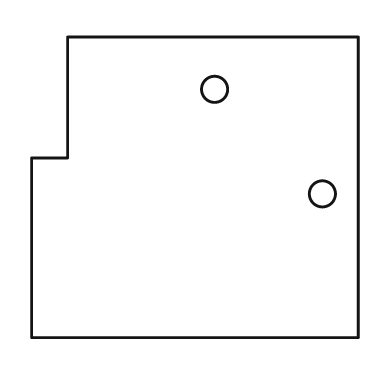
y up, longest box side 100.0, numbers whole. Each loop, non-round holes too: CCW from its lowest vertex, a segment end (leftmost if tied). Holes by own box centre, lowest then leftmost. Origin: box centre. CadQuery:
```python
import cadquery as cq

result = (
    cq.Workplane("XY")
    .moveTo(-50.0, -46.0)
    .lineTo(50.0, -46.0)
    .lineTo(50.0, 46.0)
    .lineTo(-39.0, 46.0)
    .lineTo(-39.0, 9.0)
    .lineTo(-50.0, 9.0)
    .close()
    .moveTo(39.0, -2.0)
    .circle(4.0)
    .moveTo(6.0, 30.0)
    .circle(4.0)
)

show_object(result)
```